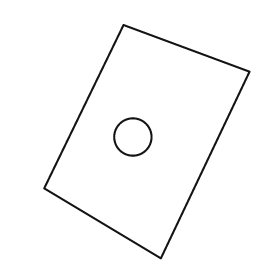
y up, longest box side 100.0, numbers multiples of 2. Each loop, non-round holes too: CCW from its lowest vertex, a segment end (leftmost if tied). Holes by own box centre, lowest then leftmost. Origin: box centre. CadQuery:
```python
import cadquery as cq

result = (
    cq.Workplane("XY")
    .moveTo(6.0, -50.0)
    .lineTo(44.0, 30.0)
    .lineTo(-10.0, 50.0)
    .lineTo(-44.0, -20.0)
    .close()
    .moveTo(-6.0, 2.0)
    .circle(8.0)
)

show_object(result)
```